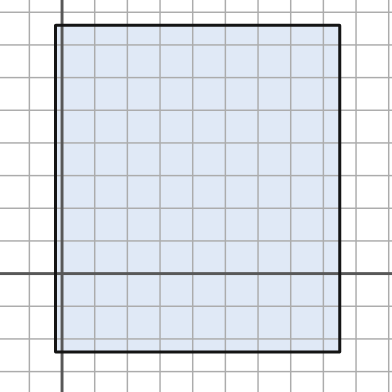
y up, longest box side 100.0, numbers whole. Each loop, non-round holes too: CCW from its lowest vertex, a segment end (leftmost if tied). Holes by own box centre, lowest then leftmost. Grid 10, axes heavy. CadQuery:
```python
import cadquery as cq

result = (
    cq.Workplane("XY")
    .moveTo(-2.0, -24.0)
    .lineTo(85.0, -24.0)
    .lineTo(85.0, 76.0)
    .lineTo(-2.0, 76.0)
    .close()
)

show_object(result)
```